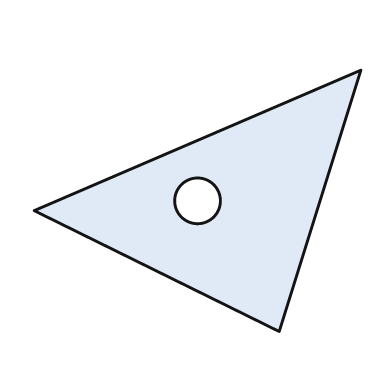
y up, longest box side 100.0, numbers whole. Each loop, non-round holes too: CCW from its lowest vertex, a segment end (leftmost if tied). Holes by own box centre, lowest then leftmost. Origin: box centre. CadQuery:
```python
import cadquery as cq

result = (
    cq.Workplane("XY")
    .moveTo(25.0, -40.0)
    .lineTo(50.0, 40.0)
    .lineTo(-50.0, -3.0)
    .close()
    .moveTo(0.0, 0.0)
    .circle(7.0)
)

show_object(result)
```